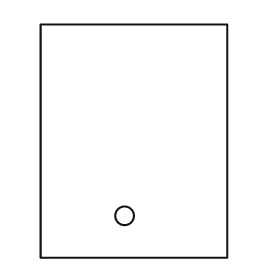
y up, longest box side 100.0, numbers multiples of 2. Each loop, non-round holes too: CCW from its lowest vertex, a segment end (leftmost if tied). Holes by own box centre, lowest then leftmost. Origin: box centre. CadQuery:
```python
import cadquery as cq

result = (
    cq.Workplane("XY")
    .moveTo(-40.0, -50.0)
    .lineTo(40.0, -50.0)
    .lineTo(40.0, 50.0)
    .lineTo(-40.0, 50.0)
    .close()
    .moveTo(-4.0, -32.0)
    .circle(4.0)
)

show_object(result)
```